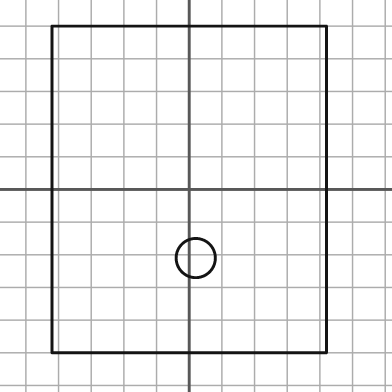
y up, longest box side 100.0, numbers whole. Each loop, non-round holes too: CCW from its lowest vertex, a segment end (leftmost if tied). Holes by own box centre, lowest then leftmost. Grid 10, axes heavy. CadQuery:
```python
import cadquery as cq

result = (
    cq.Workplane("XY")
    .moveTo(-42.0, -50.0)
    .lineTo(42.0, -50.0)
    .lineTo(42.0, 50.0)
    .lineTo(-42.0, 50.0)
    .close()
    .moveTo(2.0, -21.0)
    .circle(6.0)
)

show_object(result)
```